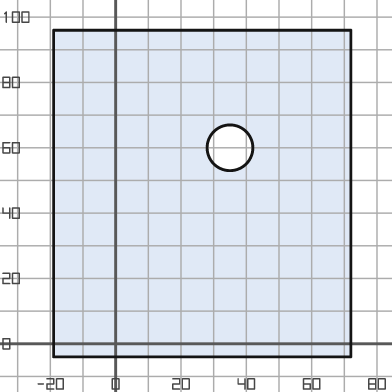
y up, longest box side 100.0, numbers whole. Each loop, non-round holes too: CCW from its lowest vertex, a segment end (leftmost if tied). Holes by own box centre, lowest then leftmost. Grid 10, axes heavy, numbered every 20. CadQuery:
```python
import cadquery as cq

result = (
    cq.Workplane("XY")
    .moveTo(-19.0, -4.0)
    .lineTo(72.0, -4.0)
    .lineTo(72.0, 96.0)
    .lineTo(-19.0, 96.0)
    .close()
    .moveTo(35.0, 60.0)
    .circle(7.0)
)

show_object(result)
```